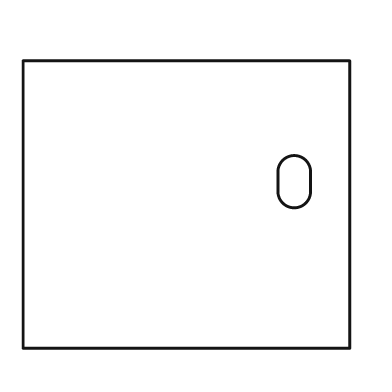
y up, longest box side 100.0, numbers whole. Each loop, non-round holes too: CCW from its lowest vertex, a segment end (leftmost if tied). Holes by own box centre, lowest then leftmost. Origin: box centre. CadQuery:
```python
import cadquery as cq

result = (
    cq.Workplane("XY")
    .moveTo(-50.0, -44.0)
    .lineTo(50.0, -44.0)
    .lineTo(50.0, 44.0)
    .lineTo(-50.0, 44.0)
    .close()
    .moveTo(28.0, 4.0)
    .threePointArc((33.0, -1.0), (38.0, 4.0))
    .lineTo(38.0, 10.0)
    .threePointArc((33.0, 15.0), (28.0, 10.0))
    .close()
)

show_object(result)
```